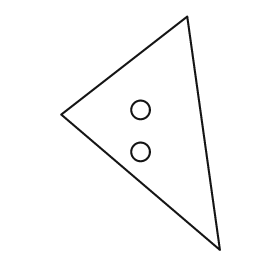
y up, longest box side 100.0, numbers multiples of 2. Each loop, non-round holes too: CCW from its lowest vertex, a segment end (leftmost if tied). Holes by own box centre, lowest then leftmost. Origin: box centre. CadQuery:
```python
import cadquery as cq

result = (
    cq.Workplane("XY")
    .moveTo(34.0, -50.0)
    .lineTo(20.0, 50.0)
    .lineTo(-34.0, 8.0)
    .close()
    .moveTo(0.0, -8.0)
    .circle(4.0)
    .moveTo(0.0, 10.0)
    .circle(4.0)
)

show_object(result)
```